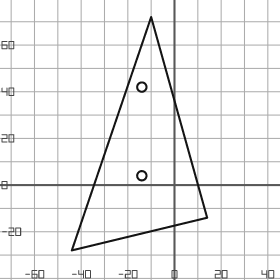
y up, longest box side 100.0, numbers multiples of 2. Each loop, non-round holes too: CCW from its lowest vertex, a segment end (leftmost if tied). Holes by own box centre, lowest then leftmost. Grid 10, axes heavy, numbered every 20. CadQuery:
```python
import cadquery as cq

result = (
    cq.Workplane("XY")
    .moveTo(-44.0, -28.0)
    .lineTo(14.0, -14.0)
    .lineTo(-10.0, 72.0)
    .close()
    .moveTo(-14.0, 4.0)
    .circle(2.0)
    .moveTo(-14.0, 42.0)
    .circle(2.0)
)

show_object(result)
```